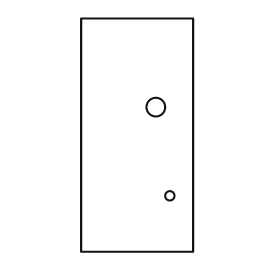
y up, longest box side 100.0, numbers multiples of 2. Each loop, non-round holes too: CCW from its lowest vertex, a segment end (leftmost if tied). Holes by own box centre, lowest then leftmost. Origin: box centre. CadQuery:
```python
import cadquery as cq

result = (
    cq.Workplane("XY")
    .moveTo(-24.0, -50.0)
    .lineTo(24.0, -50.0)
    .lineTo(24.0, 50.0)
    .lineTo(-24.0, 50.0)
    .close()
    .moveTo(14.0, -26.0)
    .circle(2.0)
    .moveTo(8.0, 12.0)
    .circle(4.0)
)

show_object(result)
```